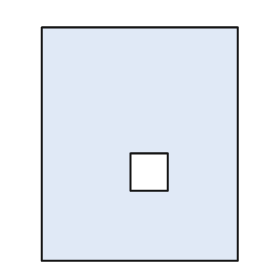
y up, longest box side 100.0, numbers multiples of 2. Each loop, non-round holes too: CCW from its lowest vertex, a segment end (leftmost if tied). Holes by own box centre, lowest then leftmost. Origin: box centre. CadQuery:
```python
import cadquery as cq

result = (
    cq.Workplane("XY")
    .moveTo(-42.0, -50.0)
    .lineTo(42.0, -50.0)
    .lineTo(42.0, 50.0)
    .lineTo(-42.0, 50.0)
    .close()
    .moveTo(-4.0, -20.0)
    .lineTo(12.0, -20.0)
    .lineTo(12.0, -4.0)
    .lineTo(-4.0, -4.0)
    .close()
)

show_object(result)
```